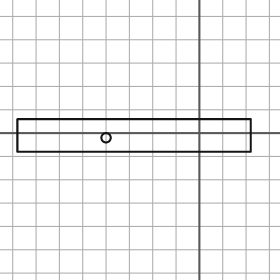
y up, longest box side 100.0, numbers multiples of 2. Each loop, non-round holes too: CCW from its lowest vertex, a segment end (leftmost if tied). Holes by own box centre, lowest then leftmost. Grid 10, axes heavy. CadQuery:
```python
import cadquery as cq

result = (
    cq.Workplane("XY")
    .moveTo(-78.0, -8.0)
    .lineTo(22.0, -8.0)
    .lineTo(22.0, 6.0)
    .lineTo(-78.0, 6.0)
    .close()
    .moveTo(-40.0, -2.0)
    .circle(2.0)
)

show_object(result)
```